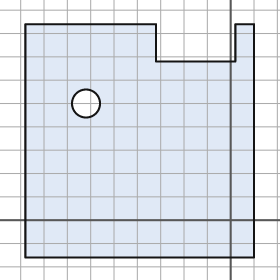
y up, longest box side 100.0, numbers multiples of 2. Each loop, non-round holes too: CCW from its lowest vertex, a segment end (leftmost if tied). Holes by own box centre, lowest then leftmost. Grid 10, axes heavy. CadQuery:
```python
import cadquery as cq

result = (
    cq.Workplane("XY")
    .moveTo(-88.0, -16.0)
    .lineTo(10.0, -16.0)
    .lineTo(10.0, 84.0)
    .lineTo(2.0, 84.0)
    .lineTo(2.0, 68.0)
    .lineTo(-32.0, 68.0)
    .lineTo(-32.0, 84.0)
    .lineTo(-88.0, 84.0)
    .close()
    .moveTo(-62.0, 50.0)
    .circle(6.0)
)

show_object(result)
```